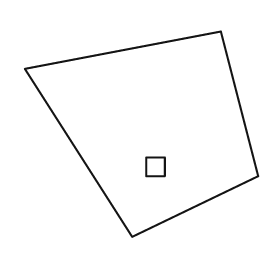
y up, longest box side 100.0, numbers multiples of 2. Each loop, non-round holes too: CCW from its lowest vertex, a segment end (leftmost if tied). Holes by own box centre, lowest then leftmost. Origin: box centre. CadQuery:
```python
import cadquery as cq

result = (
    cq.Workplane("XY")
    .moveTo(-4.0, -44.0)
    .lineTo(50.0, -18.0)
    .lineTo(34.0, 44.0)
    .lineTo(-50.0, 28.0)
    .close()
    .moveTo(2.0, -18.0)
    .lineTo(10.0, -18.0)
    .lineTo(10.0, -10.0)
    .lineTo(2.0, -10.0)
    .close()
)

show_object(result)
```